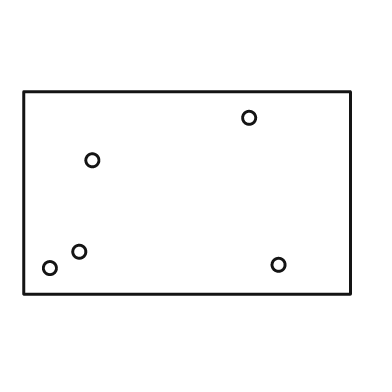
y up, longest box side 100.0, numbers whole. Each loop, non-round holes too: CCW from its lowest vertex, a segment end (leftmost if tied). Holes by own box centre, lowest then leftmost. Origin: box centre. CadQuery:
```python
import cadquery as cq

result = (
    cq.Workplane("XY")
    .moveTo(-50.0, -31.0)
    .lineTo(50.0, -31.0)
    .lineTo(50.0, 31.0)
    .lineTo(-50.0, 31.0)
    .close()
    .moveTo(-42.0, -23.0)
    .circle(2.0)
    .moveTo(28.0, -22.0)
    .circle(2.0)
    .moveTo(-33.0, -18.0)
    .circle(2.0)
    .moveTo(-29.0, 10.0)
    .circle(2.0)
    .moveTo(19.0, 23.0)
    .circle(2.0)
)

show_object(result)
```